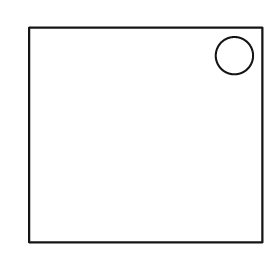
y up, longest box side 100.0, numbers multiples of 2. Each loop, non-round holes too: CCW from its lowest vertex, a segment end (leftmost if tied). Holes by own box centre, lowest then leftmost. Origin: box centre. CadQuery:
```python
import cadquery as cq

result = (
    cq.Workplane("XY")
    .moveTo(-50.0, -46.0)
    .lineTo(50.0, -46.0)
    .lineTo(50.0, 46.0)
    .lineTo(-50.0, 46.0)
    .close()
    .moveTo(38.0, 34.0)
    .circle(8.0)
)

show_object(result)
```